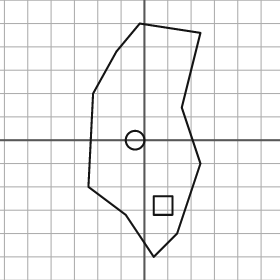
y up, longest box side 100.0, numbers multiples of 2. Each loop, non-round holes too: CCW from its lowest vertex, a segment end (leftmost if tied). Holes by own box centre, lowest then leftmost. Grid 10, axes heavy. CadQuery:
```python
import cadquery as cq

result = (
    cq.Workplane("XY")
    .moveTo(4.0, -50.0)
    .lineTo(14.0, -40.0)
    .lineTo(24.0, -10.0)
    .lineTo(16.0, 14.0)
    .lineTo(24.0, 46.0)
    .lineTo(-2.0, 50.0)
    .lineTo(-12.0, 38.0)
    .lineTo(-22.0, 20.0)
    .lineTo(-24.0, -20.0)
    .lineTo(-8.0, -32.0)
    .close()
    .moveTo(4.0, -32.0)
    .lineTo(12.0, -32.0)
    .lineTo(12.0, -24.0)
    .lineTo(4.0, -24.0)
    .close()
    .moveTo(-4.0, 0.0)
    .circle(4.0)
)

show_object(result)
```